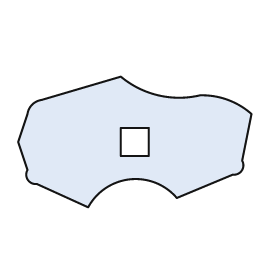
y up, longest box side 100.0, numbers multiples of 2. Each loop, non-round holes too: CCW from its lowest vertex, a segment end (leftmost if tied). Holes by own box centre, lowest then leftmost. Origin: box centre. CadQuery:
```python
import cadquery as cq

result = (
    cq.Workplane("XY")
    .moveTo(-20.0, -28.0)
    .threePointArc((-2.0, -16.0), (18.0, -24.0))
    .lineTo(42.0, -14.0)
    .threePointArc((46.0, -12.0), (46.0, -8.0))
    .lineTo(50.0, 12.0)
    .threePointArc((40.0, 18.0), (28.0, 20.0))
    .threePointArc((10.0, 20.0), (-6.0, 28.0))
    .lineTo(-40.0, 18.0)
    .threePointArc((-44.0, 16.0), (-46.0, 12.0))
    .lineTo(-50.0, 0.0)
    .lineTo(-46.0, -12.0)
    .threePointArc((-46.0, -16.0), (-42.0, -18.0))
    .close()
    .moveTo(-6.0, -6.0)
    .lineTo(6.0, -6.0)
    .lineTo(6.0, 6.0)
    .lineTo(-6.0, 6.0)
    .close()
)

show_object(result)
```